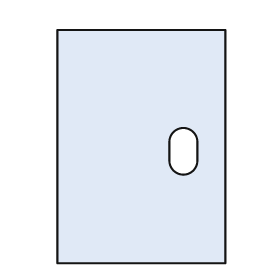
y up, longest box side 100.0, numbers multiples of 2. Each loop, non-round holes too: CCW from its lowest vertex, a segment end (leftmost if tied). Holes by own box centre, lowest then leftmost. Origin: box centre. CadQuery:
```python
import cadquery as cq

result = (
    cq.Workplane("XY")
    .moveTo(-36.0, -50.0)
    .lineTo(36.0, -50.0)
    .lineTo(36.0, 50.0)
    .lineTo(-36.0, 50.0)
    .close()
    .moveTo(12.0, -6.0)
    .threePointArc((18.0, -12.0), (24.0, -6.0))
    .lineTo(24.0, 2.0)
    .threePointArc((18.0, 8.0), (12.0, 2.0))
    .close()
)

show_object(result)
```